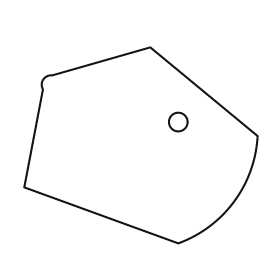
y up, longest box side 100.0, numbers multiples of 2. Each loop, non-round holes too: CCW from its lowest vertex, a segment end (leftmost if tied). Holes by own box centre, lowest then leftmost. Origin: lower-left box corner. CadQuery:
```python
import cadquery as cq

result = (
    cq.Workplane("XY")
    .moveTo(66.0, 0.0)
    .threePointArc((90.0, 18.0), (100.0, 46.0))
    .lineTo(54.0, 84.0)
    .lineTo(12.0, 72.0)
    .threePointArc((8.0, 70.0), (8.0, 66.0))
    .lineTo(0.0, 24.0)
    .close()
    .moveTo(66.0, 52.0)
    .circle(4.0)
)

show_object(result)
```